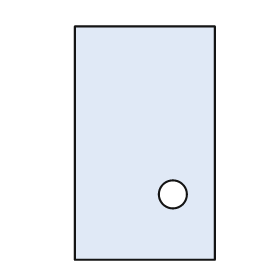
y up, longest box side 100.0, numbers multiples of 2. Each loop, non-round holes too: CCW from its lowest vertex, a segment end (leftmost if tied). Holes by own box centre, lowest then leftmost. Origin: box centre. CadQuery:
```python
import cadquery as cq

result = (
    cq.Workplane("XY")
    .moveTo(-30.0, -50.0)
    .lineTo(30.0, -50.0)
    .lineTo(30.0, 50.0)
    .lineTo(-30.0, 50.0)
    .close()
    .moveTo(12.0, -22.0)
    .circle(6.0)
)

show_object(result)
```